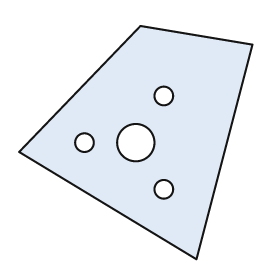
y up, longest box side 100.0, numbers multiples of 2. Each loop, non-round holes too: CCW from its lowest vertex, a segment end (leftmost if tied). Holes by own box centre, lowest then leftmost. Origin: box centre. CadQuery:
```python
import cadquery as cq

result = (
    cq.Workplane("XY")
    .moveTo(26.0, -50.0)
    .lineTo(50.0, 42.0)
    .lineTo(2.0, 50.0)
    .lineTo(-50.0, -4.0)
    .close()
    .moveTo(12.0, -20.0)
    .circle(4.0)
    .moveTo(-22.0, 0.0)
    .circle(4.0)
    .moveTo(0.0, 0.0)
    .circle(8.0)
    .moveTo(12.0, 20.0)
    .circle(4.0)
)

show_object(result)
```